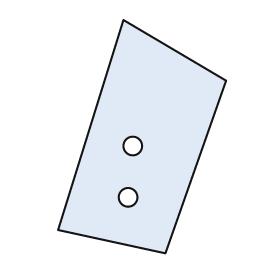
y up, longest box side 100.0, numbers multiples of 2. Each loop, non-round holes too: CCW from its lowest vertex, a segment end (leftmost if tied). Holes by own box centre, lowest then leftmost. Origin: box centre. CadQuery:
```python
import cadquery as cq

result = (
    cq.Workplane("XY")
    .moveTo(10.0, -50.0)
    .lineTo(36.0, 24.0)
    .lineTo(-8.0, 50.0)
    .lineTo(-36.0, -40.0)
    .close()
    .moveTo(-6.0, -26.0)
    .circle(4.0)
    .moveTo(-4.0, -4.0)
    .circle(4.0)
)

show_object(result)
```